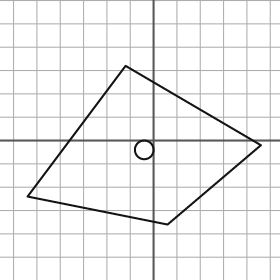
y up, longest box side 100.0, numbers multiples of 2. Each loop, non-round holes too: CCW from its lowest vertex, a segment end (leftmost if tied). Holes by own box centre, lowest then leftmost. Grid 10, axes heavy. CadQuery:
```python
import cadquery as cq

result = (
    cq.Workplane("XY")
    .moveTo(6.0, -36.0)
    .lineTo(46.0, -2.0)
    .lineTo(-12.0, 32.0)
    .lineTo(-54.0, -24.0)
    .close()
    .moveTo(-4.0, -4.0)
    .circle(4.0)
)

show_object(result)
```